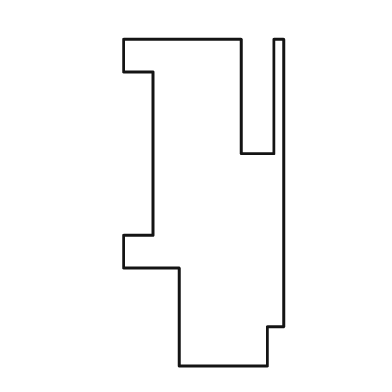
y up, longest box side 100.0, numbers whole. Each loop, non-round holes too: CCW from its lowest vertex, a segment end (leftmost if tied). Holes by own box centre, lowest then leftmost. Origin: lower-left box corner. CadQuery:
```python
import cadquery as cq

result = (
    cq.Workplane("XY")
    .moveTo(17.0, 0.0)
    .lineTo(44.0, 0.0)
    .lineTo(44.0, 12.0)
    .lineTo(49.0, 12.0)
    .lineTo(49.0, 100.0)
    .lineTo(46.0, 100.0)
    .lineTo(46.0, 65.0)
    .lineTo(36.0, 65.0)
    .lineTo(36.0, 100.0)
    .lineTo(0.0, 100.0)
    .lineTo(0.0, 90.0)
    .lineTo(9.0, 90.0)
    .lineTo(9.0, 40.0)
    .lineTo(0.0, 40.0)
    .lineTo(0.0, 30.0)
    .lineTo(17.0, 30.0)
    .close()
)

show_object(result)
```